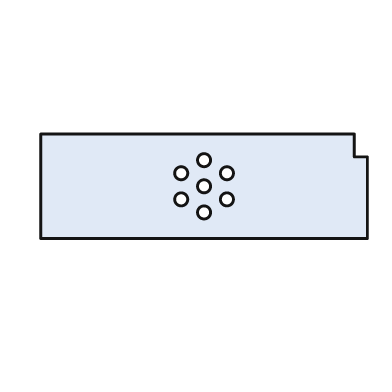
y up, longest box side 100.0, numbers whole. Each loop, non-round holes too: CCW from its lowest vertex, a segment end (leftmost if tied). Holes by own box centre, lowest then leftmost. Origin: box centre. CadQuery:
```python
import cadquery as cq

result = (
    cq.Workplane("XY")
    .moveTo(-50.0, -16.0)
    .lineTo(50.0, -16.0)
    .lineTo(50.0, 9.0)
    .lineTo(46.0, 9.0)
    .lineTo(46.0, 16.0)
    .lineTo(-50.0, 16.0)
    .close()
    .moveTo(0.0, -8.0)
    .circle(2.0)
    .moveTo(-7.0, -4.0)
    .circle(2.0)
    .moveTo(7.0, -4.0)
    .circle(2.0)
    .moveTo(0.0, 0.0)
    .circle(2.0)
    .moveTo(-7.0, 4.0)
    .circle(2.0)
    .moveTo(7.0, 4.0)
    .circle(2.0)
    .moveTo(0.0, 8.0)
    .circle(2.0)
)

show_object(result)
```